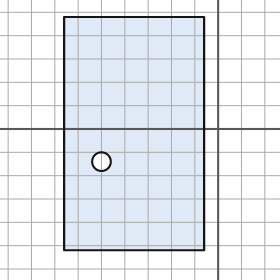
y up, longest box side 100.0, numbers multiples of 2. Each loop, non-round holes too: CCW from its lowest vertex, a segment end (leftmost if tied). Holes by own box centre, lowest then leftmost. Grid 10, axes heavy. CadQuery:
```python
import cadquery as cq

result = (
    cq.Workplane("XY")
    .moveTo(-66.0, -52.0)
    .lineTo(-6.0, -52.0)
    .lineTo(-6.0, 48.0)
    .lineTo(-66.0, 48.0)
    .close()
    .moveTo(-50.0, -14.0)
    .circle(4.0)
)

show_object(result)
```